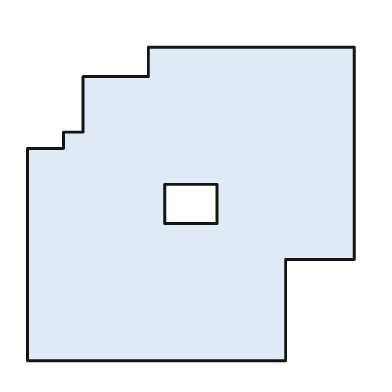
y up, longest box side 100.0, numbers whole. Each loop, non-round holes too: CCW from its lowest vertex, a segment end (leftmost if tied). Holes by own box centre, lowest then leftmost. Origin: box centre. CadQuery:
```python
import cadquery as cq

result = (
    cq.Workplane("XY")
    .moveTo(-50.0, -48.0)
    .lineTo(29.0, -48.0)
    .lineTo(29.0, -17.0)
    .lineTo(50.0, -17.0)
    .lineTo(50.0, 48.0)
    .lineTo(-13.0, 48.0)
    .lineTo(-13.0, 39.0)
    .lineTo(-33.0, 39.0)
    .lineTo(-33.0, 22.0)
    .lineTo(-39.0, 22.0)
    .lineTo(-39.0, 17.0)
    .lineTo(-50.0, 17.0)
    .close()
    .moveTo(-8.0, -6.0)
    .lineTo(8.0, -6.0)
    .lineTo(8.0, 6.0)
    .lineTo(-8.0, 6.0)
    .close()
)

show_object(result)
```